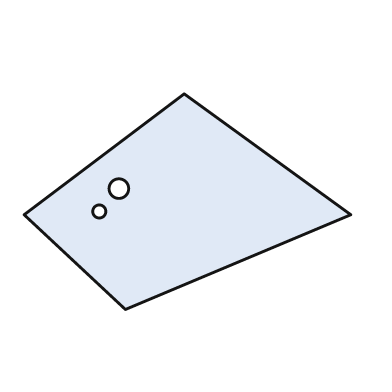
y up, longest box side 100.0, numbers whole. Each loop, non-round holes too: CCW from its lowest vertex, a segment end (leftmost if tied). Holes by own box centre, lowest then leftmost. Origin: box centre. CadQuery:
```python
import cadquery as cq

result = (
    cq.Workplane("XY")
    .moveTo(-19.0, -33.0)
    .lineTo(50.0, -4.0)
    .lineTo(-1.0, 33.0)
    .lineTo(-50.0, -4.0)
    .close()
    .moveTo(-27.0, -3.0)
    .circle(2.0)
    .moveTo(-21.0, 4.0)
    .circle(3.0)
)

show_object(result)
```